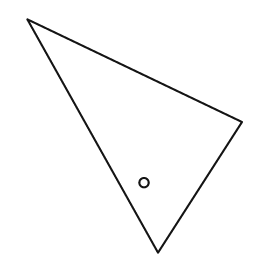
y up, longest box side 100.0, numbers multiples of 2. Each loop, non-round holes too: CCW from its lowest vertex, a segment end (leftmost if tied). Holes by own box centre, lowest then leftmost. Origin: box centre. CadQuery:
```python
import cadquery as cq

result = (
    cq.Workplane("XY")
    .moveTo(10.0, -50.0)
    .lineTo(46.0, 6.0)
    .lineTo(-46.0, 50.0)
    .close()
    .moveTo(4.0, -20.0)
    .circle(2.0)
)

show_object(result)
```